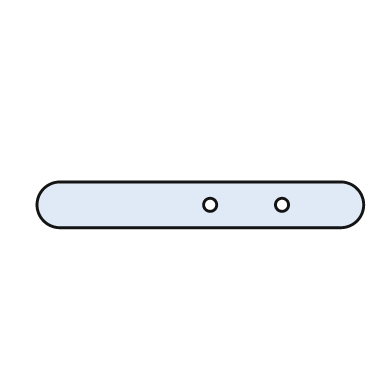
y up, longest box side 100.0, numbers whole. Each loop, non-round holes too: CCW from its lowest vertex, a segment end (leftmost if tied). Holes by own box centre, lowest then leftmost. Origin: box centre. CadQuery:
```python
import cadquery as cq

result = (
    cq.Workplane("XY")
    .moveTo(-43.0, -7.0)
    .lineTo(43.0, -7.0)
    .threePointArc((50.0, 0.0), (43.0, 7.0))
    .lineTo(-43.0, 7.0)
    .threePointArc((-50.0, 0.0), (-43.0, -7.0))
    .close()
    .moveTo(3.0, 0.0)
    .circle(2.0)
    .moveTo(25.0, 0.0)
    .circle(2.0)
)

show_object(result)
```